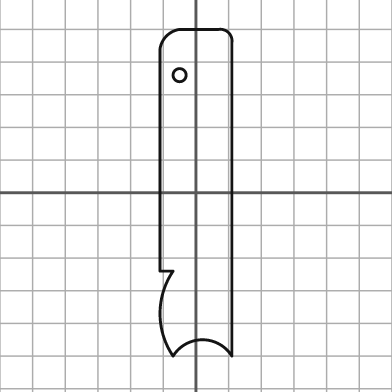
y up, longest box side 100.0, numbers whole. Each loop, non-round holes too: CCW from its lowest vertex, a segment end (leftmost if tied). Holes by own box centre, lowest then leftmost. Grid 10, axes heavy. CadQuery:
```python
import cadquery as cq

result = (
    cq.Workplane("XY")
    .moveTo(-7.0, -50.0)
    .threePointArc((2.0, -45.0), (11.0, -50.0))
    .lineTo(11.0, 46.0)
    .threePointArc((10.0, 49.0), (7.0, 50.0))
    .lineTo(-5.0, 50.0)
    .threePointArc((-9.0, 48.0), (-11.0, 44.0))
    .lineTo(-11.0, -24.0)
    .lineTo(-7.0, -24.0)
    .threePointArc((-11.0, -37.0), (-7.0, -50.0))
    .close()
    .moveTo(-5.0, 36.0)
    .circle(2.0)
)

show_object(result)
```